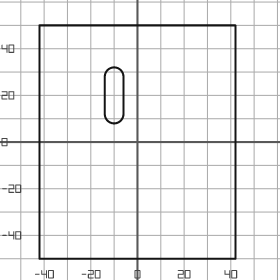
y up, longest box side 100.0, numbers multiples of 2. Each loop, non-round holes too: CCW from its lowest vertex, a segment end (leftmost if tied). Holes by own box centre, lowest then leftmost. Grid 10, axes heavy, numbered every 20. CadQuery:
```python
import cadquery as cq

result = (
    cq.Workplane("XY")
    .moveTo(-42.0, -50.0)
    .lineTo(42.0, -50.0)
    .lineTo(42.0, 50.0)
    .lineTo(-42.0, 50.0)
    .close()
    .moveTo(-14.0, 12.0)
    .threePointArc((-10.0, 8.0), (-6.0, 12.0))
    .lineTo(-6.0, 28.0)
    .threePointArc((-10.0, 32.0), (-14.0, 28.0))
    .close()
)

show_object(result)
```